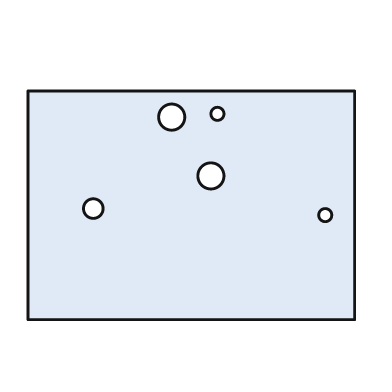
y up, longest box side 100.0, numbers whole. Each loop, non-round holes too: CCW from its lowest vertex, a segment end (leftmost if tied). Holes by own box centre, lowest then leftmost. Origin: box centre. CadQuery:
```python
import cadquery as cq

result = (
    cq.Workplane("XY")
    .moveTo(-50.0, -35.0)
    .lineTo(50.0, -35.0)
    .lineTo(50.0, 35.0)
    .lineTo(-50.0, 35.0)
    .close()
    .moveTo(41.0, -3.0)
    .circle(2.0)
    .moveTo(-30.0, -1.0)
    .circle(3.0)
    .moveTo(6.0, 9.0)
    .circle(4.0)
    .moveTo(-6.0, 27.0)
    .circle(4.0)
    .moveTo(8.0, 28.0)
    .circle(2.0)
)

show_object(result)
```